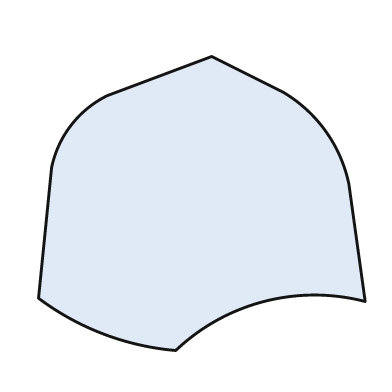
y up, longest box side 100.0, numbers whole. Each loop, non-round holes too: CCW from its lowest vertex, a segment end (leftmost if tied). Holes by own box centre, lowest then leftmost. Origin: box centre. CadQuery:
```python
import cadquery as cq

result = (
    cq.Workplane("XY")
    .moveTo(-8.0, -45.0)
    .threePointArc((19.0, -30.0), (50.0, -30.0))
    .lineTo(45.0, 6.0)
    .threePointArc((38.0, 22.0), (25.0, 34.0))
    .lineTo(3.0, 45.0)
    .lineTo(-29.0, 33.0)
    .threePointArc((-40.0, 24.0), (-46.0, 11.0))
    .lineTo(-50.0, -29.0)
    .threePointArc((-30.0, -40.0), (-8.0, -45.0))
    .close()
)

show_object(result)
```